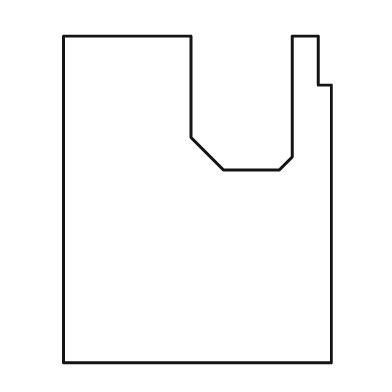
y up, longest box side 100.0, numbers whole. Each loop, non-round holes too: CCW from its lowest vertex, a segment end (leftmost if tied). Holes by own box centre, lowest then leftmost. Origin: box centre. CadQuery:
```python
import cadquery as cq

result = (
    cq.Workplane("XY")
    .moveTo(-41.0, -50.0)
    .lineTo(41.0, -50.0)
    .lineTo(41.0, 35.0)
    .lineTo(37.0, 35.0)
    .lineTo(37.0, 50.0)
    .lineTo(29.0, 50.0)
    .lineTo(29.0, 13.0)
    .lineTo(25.0, 9.0)
    .lineTo(8.0, 9.0)
    .lineTo(-2.0, 19.0)
    .lineTo(-2.0, 50.0)
    .lineTo(-41.0, 50.0)
    .close()
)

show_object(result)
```